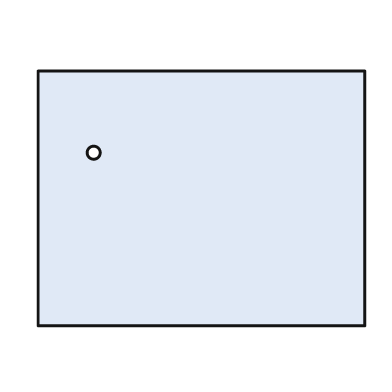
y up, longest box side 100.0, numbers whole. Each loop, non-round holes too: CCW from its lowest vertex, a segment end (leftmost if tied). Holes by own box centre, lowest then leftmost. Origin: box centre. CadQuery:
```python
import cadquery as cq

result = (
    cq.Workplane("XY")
    .moveTo(-50.0, -39.0)
    .lineTo(50.0, -39.0)
    .lineTo(50.0, 39.0)
    .lineTo(-50.0, 39.0)
    .close()
    .moveTo(-33.0, 14.0)
    .circle(2.0)
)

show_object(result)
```